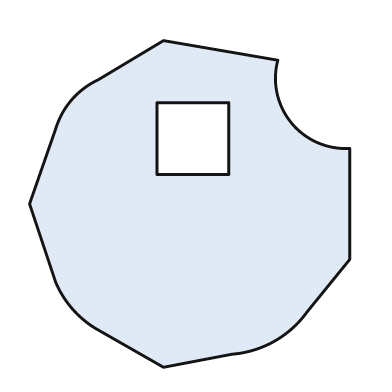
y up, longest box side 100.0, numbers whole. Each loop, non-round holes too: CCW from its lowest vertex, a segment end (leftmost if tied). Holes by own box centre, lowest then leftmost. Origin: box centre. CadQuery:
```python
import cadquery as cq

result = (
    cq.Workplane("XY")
    .moveTo(-8.0, -50.0)
    .lineTo(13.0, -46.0)
    .threePointArc((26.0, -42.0), (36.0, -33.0))
    .lineTo(49.0, -17.0)
    .lineTo(49.0, 17.0)
    .threePointArc((31.0, 25.0), (27.0, 44.0))
    .lineTo(-8.0, 50.0)
    .lineTo(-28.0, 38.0)
    .threePointArc((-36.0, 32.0), (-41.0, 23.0))
    .lineTo(-49.0, 0.0)
    .lineTo(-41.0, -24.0)
    .threePointArc((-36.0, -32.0), (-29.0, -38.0))
    .close()
    .moveTo(-10.0, 9.0)
    .lineTo(12.0, 9.0)
    .lineTo(12.0, 31.0)
    .lineTo(-10.0, 31.0)
    .close()
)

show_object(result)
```